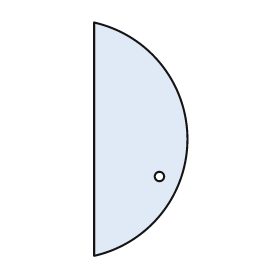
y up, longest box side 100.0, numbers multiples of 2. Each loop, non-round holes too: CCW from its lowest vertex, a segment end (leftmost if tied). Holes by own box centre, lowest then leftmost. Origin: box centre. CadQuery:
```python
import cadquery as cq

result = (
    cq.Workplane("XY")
    .moveTo(-20.0, -50.0)
    .threePointArc((20.0, 0.0), (-20.0, 50.0))
    .close()
    .moveTo(8.0, -16.0)
    .circle(2.0)
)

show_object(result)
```